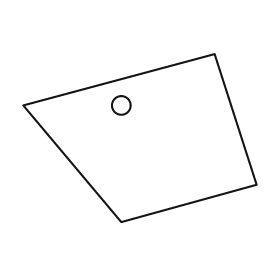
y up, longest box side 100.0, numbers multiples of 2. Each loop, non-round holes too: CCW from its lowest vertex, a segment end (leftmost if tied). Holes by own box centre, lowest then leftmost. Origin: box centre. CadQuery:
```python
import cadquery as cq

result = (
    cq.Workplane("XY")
    .moveTo(-8.0, -36.0)
    .lineTo(50.0, -20.0)
    .lineTo(32.0, 36.0)
    .lineTo(-50.0, 14.0)
    .close()
    .moveTo(-8.0, 14.0)
    .circle(4.0)
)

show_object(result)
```